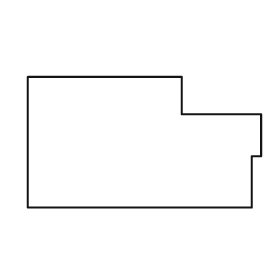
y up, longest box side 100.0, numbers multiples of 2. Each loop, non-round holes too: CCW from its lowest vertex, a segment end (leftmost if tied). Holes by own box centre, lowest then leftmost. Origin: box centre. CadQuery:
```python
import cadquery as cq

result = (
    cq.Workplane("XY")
    .moveTo(-50.0, -28.0)
    .lineTo(46.0, -28.0)
    .lineTo(46.0, -6.0)
    .lineTo(50.0, -6.0)
    .lineTo(50.0, 12.0)
    .lineTo(16.0, 12.0)
    .lineTo(16.0, 28.0)
    .lineTo(-50.0, 28.0)
    .close()
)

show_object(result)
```